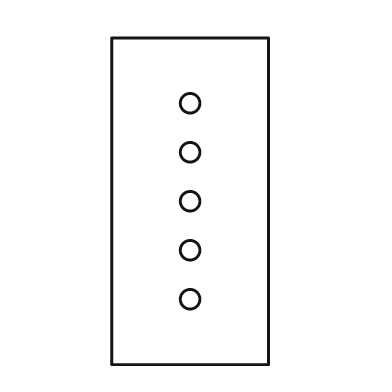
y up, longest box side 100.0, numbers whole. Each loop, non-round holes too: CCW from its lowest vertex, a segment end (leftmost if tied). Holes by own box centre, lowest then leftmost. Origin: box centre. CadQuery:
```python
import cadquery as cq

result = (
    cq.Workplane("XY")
    .moveTo(-24.0, -50.0)
    .lineTo(24.0, -50.0)
    .lineTo(24.0, 50.0)
    .lineTo(-24.0, 50.0)
    .close()
    .moveTo(0.0, -30.0)
    .circle(3.0)
    .moveTo(0.0, -15.0)
    .circle(3.0)
    .moveTo(0.0, 0.0)
    .circle(3.0)
    .moveTo(0.0, 15.0)
    .circle(3.0)
    .moveTo(0.0, 30.0)
    .circle(3.0)
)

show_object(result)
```